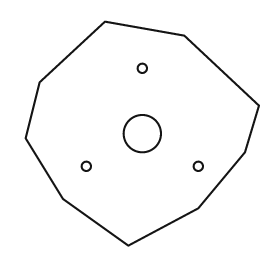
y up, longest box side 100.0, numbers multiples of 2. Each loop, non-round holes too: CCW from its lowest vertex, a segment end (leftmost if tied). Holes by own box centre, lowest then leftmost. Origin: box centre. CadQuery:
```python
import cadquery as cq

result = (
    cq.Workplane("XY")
    .moveTo(-6.0, -48.0)
    .lineTo(24.0, -32.0)
    .lineTo(44.0, -8.0)
    .lineTo(50.0, 12.0)
    .lineTo(18.0, 42.0)
    .lineTo(-16.0, 48.0)
    .lineTo(-44.0, 22.0)
    .lineTo(-50.0, -2.0)
    .lineTo(-34.0, -28.0)
    .close()
    .moveTo(-24.0, -14.0)
    .circle(2.0)
    .moveTo(24.0, -14.0)
    .circle(2.0)
    .moveTo(0.0, 0.0)
    .circle(8.0)
    .moveTo(0.0, 28.0)
    .circle(2.0)
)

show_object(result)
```